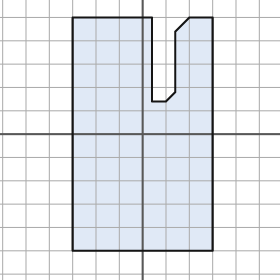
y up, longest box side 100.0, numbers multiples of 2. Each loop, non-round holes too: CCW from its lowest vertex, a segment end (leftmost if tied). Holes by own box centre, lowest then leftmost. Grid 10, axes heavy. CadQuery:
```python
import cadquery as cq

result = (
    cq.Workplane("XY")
    .moveTo(-30.0, -50.0)
    .lineTo(30.0, -50.0)
    .lineTo(30.0, 50.0)
    .lineTo(20.0, 50.0)
    .lineTo(14.0, 44.0)
    .lineTo(14.0, 18.0)
    .lineTo(10.0, 14.0)
    .lineTo(4.0, 14.0)
    .lineTo(4.0, 50.0)
    .lineTo(-30.0, 50.0)
    .close()
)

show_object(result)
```